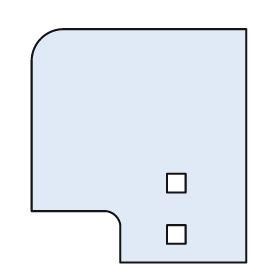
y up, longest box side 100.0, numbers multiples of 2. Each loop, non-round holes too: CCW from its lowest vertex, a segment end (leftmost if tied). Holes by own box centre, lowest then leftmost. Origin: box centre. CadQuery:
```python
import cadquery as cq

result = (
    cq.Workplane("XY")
    .moveTo(-8.0, -50.0)
    .lineTo(46.0, -50.0)
    .lineTo(46.0, 50.0)
    .lineTo(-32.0, 50.0)
    .threePointArc((-42.0, 46.0), (-46.0, 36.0))
    .lineTo(-46.0, -28.0)
    .lineTo(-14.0, -28.0)
    .threePointArc((-10.0, -30.0), (-8.0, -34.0))
    .close()
    .moveTo(12.0, -42.0)
    .lineTo(20.0, -42.0)
    .lineTo(20.0, -34.0)
    .lineTo(12.0, -34.0)
    .close()
    .moveTo(12.0, -20.0)
    .lineTo(20.0, -20.0)
    .lineTo(20.0, -12.0)
    .lineTo(12.0, -12.0)
    .close()
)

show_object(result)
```